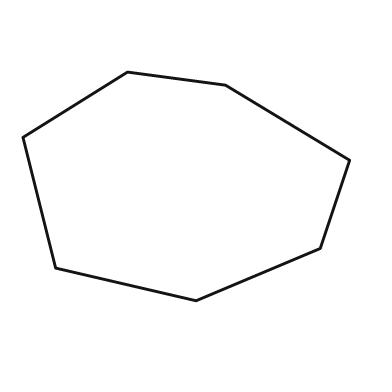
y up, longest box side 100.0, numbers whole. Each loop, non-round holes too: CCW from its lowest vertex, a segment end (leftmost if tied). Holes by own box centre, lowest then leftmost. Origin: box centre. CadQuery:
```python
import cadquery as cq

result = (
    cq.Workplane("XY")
    .moveTo(3.0, -35.0)
    .lineTo(41.0, -19.0)
    .lineTo(50.0, 8.0)
    .lineTo(12.0, 31.0)
    .lineTo(-18.0, 35.0)
    .lineTo(-50.0, 15.0)
    .lineTo(-40.0, -25.0)
    .close()
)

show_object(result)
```